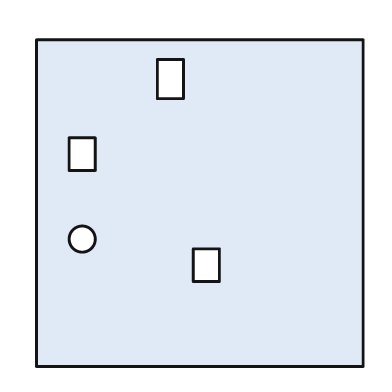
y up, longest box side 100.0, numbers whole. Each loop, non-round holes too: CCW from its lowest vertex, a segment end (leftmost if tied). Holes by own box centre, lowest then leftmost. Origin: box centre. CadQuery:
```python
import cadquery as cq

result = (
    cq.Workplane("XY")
    .moveTo(-50.0, -50.0)
    .lineTo(50.0, -50.0)
    .lineTo(50.0, 50.0)
    .lineTo(-50.0, 50.0)
    .close()
    .moveTo(-2.0, -24.0)
    .lineTo(6.0, -24.0)
    .lineTo(6.0, -14.0)
    .lineTo(-2.0, -14.0)
    .close()
    .moveTo(-36.0, -11.0)
    .circle(4.0)
    .moveTo(-40.0, 10.0)
    .lineTo(-32.0, 10.0)
    .lineTo(-32.0, 20.0)
    .lineTo(-40.0, 20.0)
    .close()
    .moveTo(-13.0, 32.0)
    .lineTo(-5.0, 32.0)
    .lineTo(-5.0, 44.0)
    .lineTo(-13.0, 44.0)
    .close()
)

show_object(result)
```